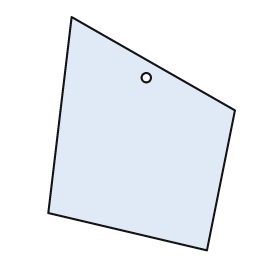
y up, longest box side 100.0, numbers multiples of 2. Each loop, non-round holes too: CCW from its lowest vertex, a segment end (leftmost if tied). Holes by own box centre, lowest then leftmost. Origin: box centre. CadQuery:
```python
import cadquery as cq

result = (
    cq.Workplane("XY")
    .moveTo(28.0, -50.0)
    .lineTo(40.0, 10.0)
    .lineTo(-30.0, 50.0)
    .lineTo(-40.0, -34.0)
    .close()
    .moveTo(2.0, 24.0)
    .circle(2.0)
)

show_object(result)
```